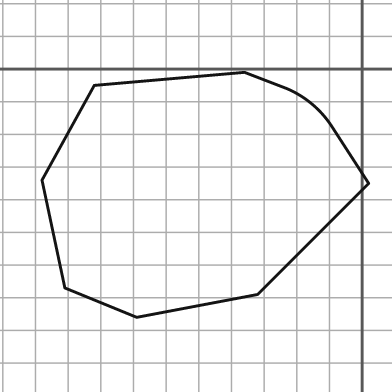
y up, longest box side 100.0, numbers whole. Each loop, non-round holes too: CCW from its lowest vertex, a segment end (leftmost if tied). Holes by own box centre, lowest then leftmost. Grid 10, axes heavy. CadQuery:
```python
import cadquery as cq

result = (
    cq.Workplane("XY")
    .moveTo(-69.0, -76.0)
    .lineTo(-32.0, -69.0)
    .lineTo(2.0, -35.0)
    .lineTo(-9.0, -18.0)
    .threePointArc((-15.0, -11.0), (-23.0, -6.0))
    .lineTo(-36.0, -1.0)
    .lineTo(-82.0, -5.0)
    .lineTo(-98.0, -34.0)
    .lineTo(-91.0, -67.0)
    .close()
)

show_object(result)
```